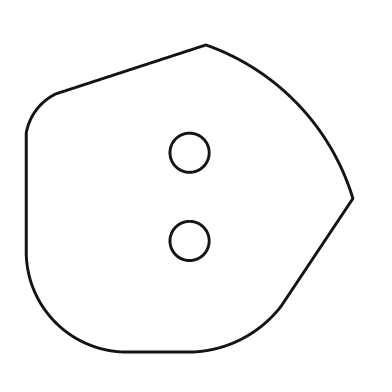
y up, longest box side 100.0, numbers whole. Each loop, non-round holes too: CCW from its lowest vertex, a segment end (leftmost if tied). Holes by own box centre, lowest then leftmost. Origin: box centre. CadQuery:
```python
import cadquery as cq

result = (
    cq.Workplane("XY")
    .moveTo(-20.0, -47.0)
    .lineTo(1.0, -47.0)
    .threePointArc((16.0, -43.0), (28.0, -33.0))
    .lineTo(50.0, 0.0)
    .threePointArc((33.0, 29.0), (5.0, 47.0))
    .lineTo(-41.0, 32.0)
    .threePointArc((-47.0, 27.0), (-50.0, 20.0))
    .lineTo(-50.0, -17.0)
    .threePointArc((-41.0, -38.0), (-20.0, -47.0))
    .close()
    .moveTo(0.0, -13.0)
    .circle(6.0)
    .moveTo(0.0, 14.0)
    .circle(6.0)
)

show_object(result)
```